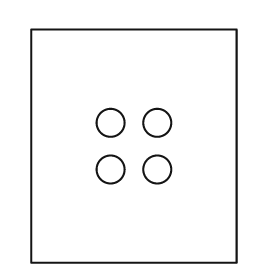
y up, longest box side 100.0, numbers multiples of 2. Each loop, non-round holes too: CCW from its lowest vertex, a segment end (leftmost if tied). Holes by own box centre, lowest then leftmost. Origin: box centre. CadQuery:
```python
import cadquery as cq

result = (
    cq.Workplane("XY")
    .moveTo(-44.0, -50.0)
    .lineTo(44.0, -50.0)
    .lineTo(44.0, 50.0)
    .lineTo(-44.0, 50.0)
    .close()
    .moveTo(-10.0, -10.0)
    .circle(6.0)
    .moveTo(10.0, -10.0)
    .circle(6.0)
    .moveTo(-10.0, 10.0)
    .circle(6.0)
    .moveTo(10.0, 10.0)
    .circle(6.0)
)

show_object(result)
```